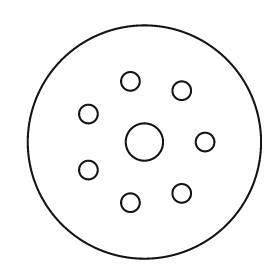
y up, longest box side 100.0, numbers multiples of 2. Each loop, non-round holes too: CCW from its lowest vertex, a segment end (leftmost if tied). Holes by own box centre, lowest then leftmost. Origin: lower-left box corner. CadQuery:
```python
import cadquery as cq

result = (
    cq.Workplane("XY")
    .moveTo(50.0, 50.0)
    .circle(50.0)
    .moveTo(44.0, 24.0)
    .circle(4.0)
    .moveTo(66.0, 28.0)
    .circle(4.0)
    .moveTo(26.0, 38.0)
    .circle(4.0)
    .moveTo(50.0, 50.0)
    .circle(8.0)
    .moveTo(76.0, 50.0)
    .circle(4.0)
    .moveTo(26.0, 62.0)
    .circle(4.0)
    .moveTo(66.0, 72.0)
    .circle(4.0)
    .moveTo(44.0, 76.0)
    .circle(4.0)
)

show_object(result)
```